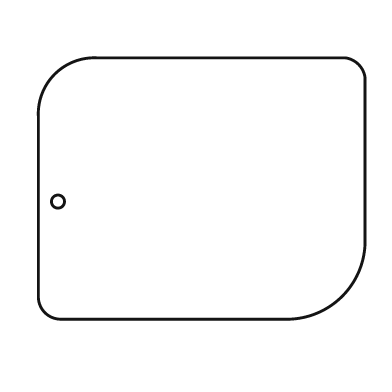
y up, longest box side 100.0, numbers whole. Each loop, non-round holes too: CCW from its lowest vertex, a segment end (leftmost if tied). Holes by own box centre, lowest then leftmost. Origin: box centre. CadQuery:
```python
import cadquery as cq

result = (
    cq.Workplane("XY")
    .moveTo(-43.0, -40.0)
    .lineTo(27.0, -40.0)
    .threePointArc((43.0, -33.0), (50.0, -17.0))
    .lineTo(50.0, 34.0)
    .threePointArc((48.0, 38.0), (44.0, 40.0))
    .lineTo(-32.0, 40.0)
    .threePointArc((-45.0, 35.0), (-50.0, 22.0))
    .lineTo(-50.0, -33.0)
    .threePointArc((-48.0, -38.0), (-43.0, -40.0))
    .close()
    .moveTo(-44.0, -4.0)
    .circle(2.0)
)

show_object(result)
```